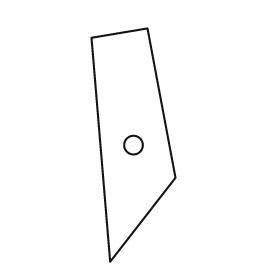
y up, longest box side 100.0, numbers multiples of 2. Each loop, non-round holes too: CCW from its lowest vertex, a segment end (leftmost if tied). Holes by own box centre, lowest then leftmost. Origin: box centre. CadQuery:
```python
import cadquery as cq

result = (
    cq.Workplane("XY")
    .moveTo(-10.0, -50.0)
    .lineTo(18.0, -14.0)
    .lineTo(6.0, 50.0)
    .lineTo(-18.0, 46.0)
    .close()
    .moveTo(0.0, 0.0)
    .circle(4.0)
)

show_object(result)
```